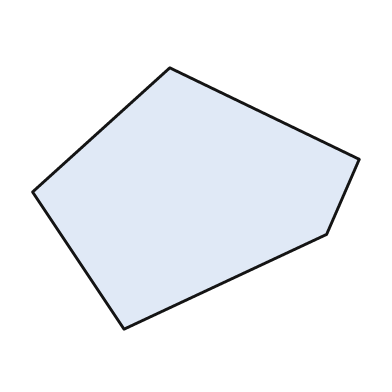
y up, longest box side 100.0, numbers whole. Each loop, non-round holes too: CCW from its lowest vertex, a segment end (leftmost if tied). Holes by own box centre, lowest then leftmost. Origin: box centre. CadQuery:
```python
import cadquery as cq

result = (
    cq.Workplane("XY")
    .moveTo(-22.0, -40.0)
    .lineTo(40.0, -11.0)
    .lineTo(50.0, 12.0)
    .lineTo(-8.0, 40.0)
    .lineTo(-50.0, 2.0)
    .close()
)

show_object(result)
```